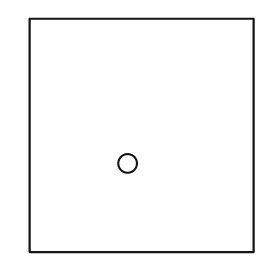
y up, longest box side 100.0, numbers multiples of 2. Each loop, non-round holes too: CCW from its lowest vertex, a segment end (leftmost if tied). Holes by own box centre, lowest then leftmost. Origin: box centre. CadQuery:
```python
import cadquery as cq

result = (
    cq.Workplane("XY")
    .moveTo(-48.0, -50.0)
    .lineTo(48.0, -50.0)
    .lineTo(48.0, 50.0)
    .lineTo(-48.0, 50.0)
    .close()
    .moveTo(-6.0, -12.0)
    .circle(4.0)
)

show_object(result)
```